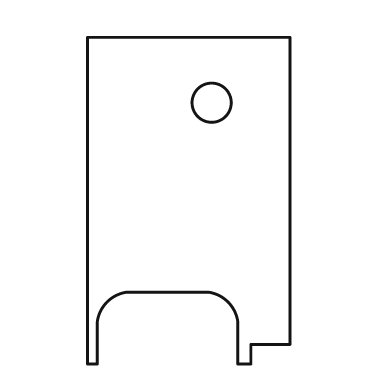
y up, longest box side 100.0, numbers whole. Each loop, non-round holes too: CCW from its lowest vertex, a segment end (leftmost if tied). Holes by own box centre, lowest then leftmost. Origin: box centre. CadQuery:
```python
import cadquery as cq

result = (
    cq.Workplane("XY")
    .moveTo(-31.0, -50.0)
    .lineTo(-28.0, -50.0)
    .lineTo(-28.0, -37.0)
    .threePointArc((-25.0, -31.0), (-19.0, -28.0))
    .lineTo(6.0, -28.0)
    .threePointArc((12.0, -31.0), (15.0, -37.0))
    .lineTo(15.0, -50.0)
    .lineTo(19.0, -50.0)
    .lineTo(19.0, -44.0)
    .lineTo(31.0, -44.0)
    .lineTo(31.0, 50.0)
    .lineTo(-31.0, 50.0)
    .close()
    .moveTo(7.0, 30.0)
    .circle(6.0)
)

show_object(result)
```